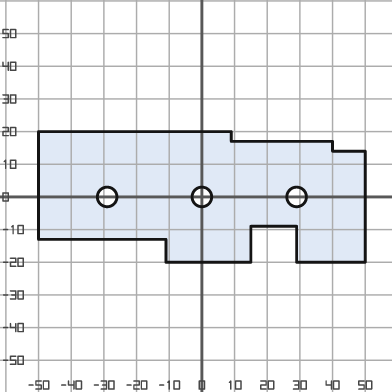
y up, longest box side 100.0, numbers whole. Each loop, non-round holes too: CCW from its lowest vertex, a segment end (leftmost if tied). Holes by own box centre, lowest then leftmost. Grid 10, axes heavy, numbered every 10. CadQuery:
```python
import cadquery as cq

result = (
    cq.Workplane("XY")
    .moveTo(-11.0, -20.0)
    .lineTo(15.0, -20.0)
    .lineTo(15.0, -9.0)
    .lineTo(29.0, -9.0)
    .lineTo(29.0, -20.0)
    .lineTo(50.0, -20.0)
    .lineTo(50.0, 14.0)
    .lineTo(40.0, 14.0)
    .lineTo(40.0, 17.0)
    .lineTo(9.0, 17.0)
    .lineTo(9.0, 20.0)
    .lineTo(-50.0, 20.0)
    .lineTo(-50.0, -13.0)
    .lineTo(-11.0, -13.0)
    .close()
    .moveTo(-29.0, 0.0)
    .circle(3.0)
    .moveTo(0.0, 0.0)
    .circle(3.0)
    .moveTo(29.0, 0.0)
    .circle(3.0)
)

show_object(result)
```